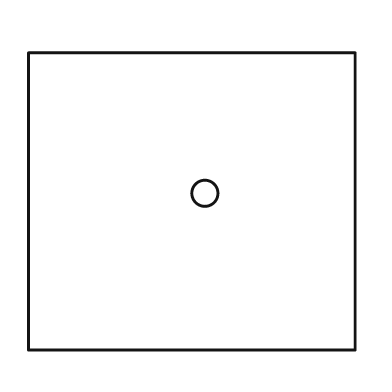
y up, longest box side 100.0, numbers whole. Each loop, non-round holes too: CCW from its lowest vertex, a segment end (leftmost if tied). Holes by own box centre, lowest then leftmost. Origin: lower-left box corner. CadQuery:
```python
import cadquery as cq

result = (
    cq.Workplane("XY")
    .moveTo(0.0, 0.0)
    .lineTo(100.0, 0.0)
    .lineTo(100.0, 91.0)
    .lineTo(0.0, 91.0)
    .close()
    .moveTo(54.0, 48.0)
    .circle(4.0)
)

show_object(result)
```